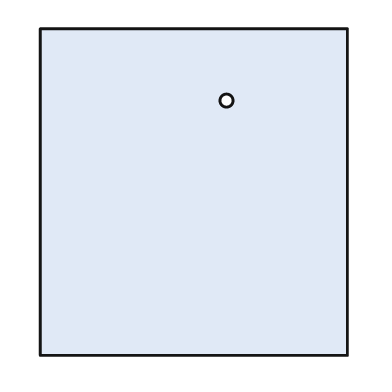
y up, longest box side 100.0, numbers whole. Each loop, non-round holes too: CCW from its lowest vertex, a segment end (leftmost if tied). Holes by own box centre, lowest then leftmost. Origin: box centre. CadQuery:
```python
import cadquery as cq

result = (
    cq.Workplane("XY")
    .moveTo(-47.0, -50.0)
    .lineTo(47.0, -50.0)
    .lineTo(47.0, 50.0)
    .lineTo(-47.0, 50.0)
    .close()
    .moveTo(10.0, 28.0)
    .circle(2.0)
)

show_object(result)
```